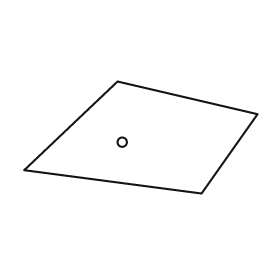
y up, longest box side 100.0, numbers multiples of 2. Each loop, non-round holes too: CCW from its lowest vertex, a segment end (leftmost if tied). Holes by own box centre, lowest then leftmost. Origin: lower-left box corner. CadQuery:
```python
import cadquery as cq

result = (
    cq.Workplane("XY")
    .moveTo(76.0, 0.0)
    .lineTo(100.0, 34.0)
    .lineTo(40.0, 48.0)
    .lineTo(0.0, 10.0)
    .close()
    .moveTo(42.0, 22.0)
    .circle(2.0)
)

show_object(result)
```